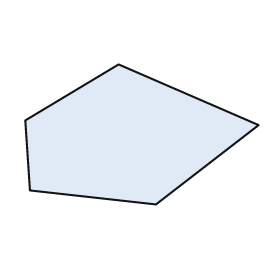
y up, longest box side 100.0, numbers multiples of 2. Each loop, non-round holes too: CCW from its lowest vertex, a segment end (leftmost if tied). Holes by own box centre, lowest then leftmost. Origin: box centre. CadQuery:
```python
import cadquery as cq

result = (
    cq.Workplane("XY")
    .moveTo(6.0, -30.0)
    .lineTo(50.0, 4.0)
    .lineTo(-10.0, 30.0)
    .lineTo(-50.0, 6.0)
    .lineTo(-48.0, -24.0)
    .close()
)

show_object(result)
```